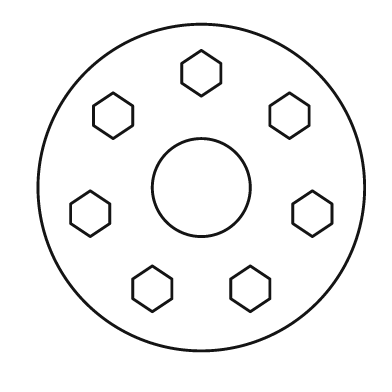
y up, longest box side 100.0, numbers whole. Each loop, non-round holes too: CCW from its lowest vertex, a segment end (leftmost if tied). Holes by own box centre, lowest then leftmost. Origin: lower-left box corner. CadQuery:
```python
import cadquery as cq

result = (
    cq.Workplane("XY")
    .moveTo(50.0, 50.0)
    .circle(50.0)
    .moveTo(35.0, 12.0)
    .lineTo(41.0, 16.0)
    .lineTo(41.0, 22.0)
    .lineTo(35.0, 26.0)
    .lineTo(29.0, 22.0)
    .lineTo(29.0, 16.0)
    .close()
    .moveTo(65.0, 12.0)
    .lineTo(71.0, 16.0)
    .lineTo(71.0, 22.0)
    .lineTo(65.0, 26.0)
    .lineTo(59.0, 22.0)
    .lineTo(59.0, 16.0)
    .close()
    .moveTo(16.0, 35.0)
    .lineTo(22.0, 39.0)
    .lineTo(22.0, 45.0)
    .lineTo(16.0, 49.0)
    .lineTo(10.0, 45.0)
    .lineTo(10.0, 39.0)
    .close()
    .moveTo(84.0, 35.0)
    .lineTo(90.0, 39.0)
    .lineTo(90.0, 45.0)
    .lineTo(84.0, 49.0)
    .lineTo(78.0, 45.0)
    .lineTo(78.0, 39.0)
    .close()
    .moveTo(50.0, 50.0)
    .circle(15.0)
    .moveTo(23.0, 65.0)
    .lineTo(29.0, 69.0)
    .lineTo(29.0, 75.0)
    .lineTo(23.0, 79.0)
    .lineTo(17.0, 75.0)
    .lineTo(17.0, 69.0)
    .close()
    .moveTo(77.0, 65.0)
    .lineTo(83.0, 69.0)
    .lineTo(83.0, 75.0)
    .lineTo(77.0, 79.0)
    .lineTo(71.0, 75.0)
    .lineTo(71.0, 69.0)
    .close()
    .moveTo(50.0, 78.0)
    .lineTo(56.0, 82.0)
    .lineTo(56.0, 88.0)
    .lineTo(50.0, 92.0)
    .lineTo(44.0, 88.0)
    .lineTo(44.0, 82.0)
    .close()
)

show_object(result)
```